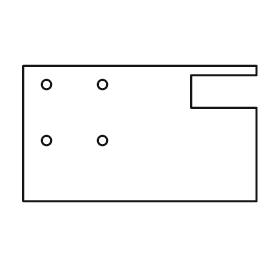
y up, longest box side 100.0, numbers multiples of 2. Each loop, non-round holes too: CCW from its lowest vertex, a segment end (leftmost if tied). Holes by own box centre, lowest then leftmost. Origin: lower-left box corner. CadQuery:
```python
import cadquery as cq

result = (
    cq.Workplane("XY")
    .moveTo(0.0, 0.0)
    .lineTo(100.0, 0.0)
    .lineTo(100.0, 40.0)
    .lineTo(72.0, 40.0)
    .lineTo(72.0, 54.0)
    .lineTo(100.0, 54.0)
    .lineTo(100.0, 58.0)
    .lineTo(0.0, 58.0)
    .close()
    .moveTo(10.0, 26.0)
    .circle(2.0)
    .moveTo(34.0, 26.0)
    .circle(2.0)
    .moveTo(10.0, 50.0)
    .circle(2.0)
    .moveTo(34.0, 50.0)
    .circle(2.0)
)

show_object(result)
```